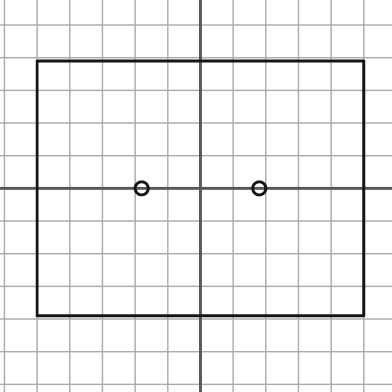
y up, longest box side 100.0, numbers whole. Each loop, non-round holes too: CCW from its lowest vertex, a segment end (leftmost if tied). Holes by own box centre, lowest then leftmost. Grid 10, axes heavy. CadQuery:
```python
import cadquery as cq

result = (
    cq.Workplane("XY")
    .moveTo(-50.0, -39.0)
    .lineTo(50.0, -39.0)
    .lineTo(50.0, 39.0)
    .lineTo(-50.0, 39.0)
    .close()
    .moveTo(-18.0, 0.0)
    .circle(2.0)
    .moveTo(18.0, 0.0)
    .circle(2.0)
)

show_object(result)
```